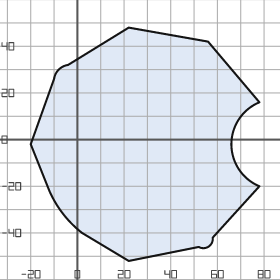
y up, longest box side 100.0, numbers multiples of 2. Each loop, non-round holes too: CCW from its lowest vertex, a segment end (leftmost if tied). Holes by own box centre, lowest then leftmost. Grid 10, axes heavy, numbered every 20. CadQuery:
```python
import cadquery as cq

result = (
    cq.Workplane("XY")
    .moveTo(22.0, -52.0)
    .lineTo(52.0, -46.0)
    .threePointArc((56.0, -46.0), (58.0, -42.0))
    .lineTo(78.0, -20.0)
    .threePointArc((66.0, -2.0), (78.0, 16.0))
    .lineTo(56.0, 42.0)
    .lineTo(22.0, 48.0)
    .lineTo(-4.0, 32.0)
    .threePointArc((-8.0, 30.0), (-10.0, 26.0))
    .lineTo(-20.0, -2.0)
    .lineTo(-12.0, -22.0)
    .threePointArc((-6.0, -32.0), (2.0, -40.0))
    .close()
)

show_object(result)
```